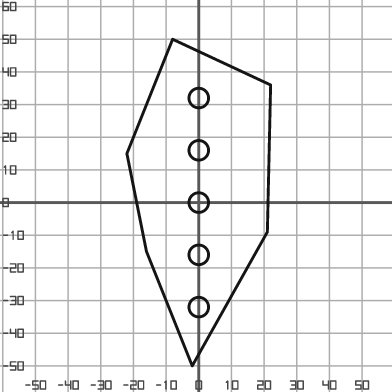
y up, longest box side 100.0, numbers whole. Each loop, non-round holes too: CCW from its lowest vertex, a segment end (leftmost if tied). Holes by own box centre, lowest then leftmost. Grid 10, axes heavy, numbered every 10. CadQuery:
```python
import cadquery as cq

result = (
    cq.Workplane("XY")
    .moveTo(-2.0, -50.0)
    .lineTo(21.0, -9.0)
    .lineTo(22.0, 36.0)
    .lineTo(-8.0, 50.0)
    .lineTo(-22.0, 15.0)
    .lineTo(-16.0, -15.0)
    .close()
    .moveTo(0.0, -32.0)
    .circle(3.0)
    .moveTo(0.0, -16.0)
    .circle(3.0)
    .moveTo(0.0, 0.0)
    .circle(3.0)
    .moveTo(0.0, 16.0)
    .circle(3.0)
    .moveTo(0.0, 32.0)
    .circle(3.0)
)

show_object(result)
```